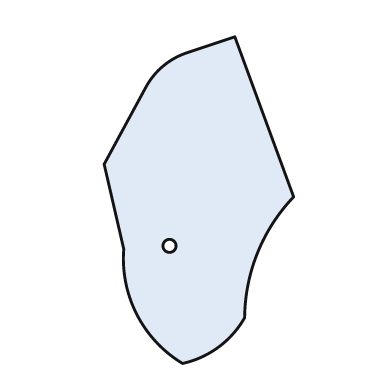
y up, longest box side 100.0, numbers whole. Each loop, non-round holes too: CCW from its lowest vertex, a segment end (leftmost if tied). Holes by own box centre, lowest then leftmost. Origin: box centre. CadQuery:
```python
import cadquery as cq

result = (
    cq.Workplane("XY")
    .moveTo(-5.0, -50.0)
    .threePointArc((6.0, -45.0), (14.0, -36.0))
    .threePointArc((18.0, -16.0), (29.0, 1.0))
    .lineTo(11.0, 50.0)
    .lineTo(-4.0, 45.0)
    .threePointArc((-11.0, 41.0), (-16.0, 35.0))
    .lineTo(-29.0, 11.0)
    .lineTo(-23.0, -15.0)
    .threePointArc((-19.0, -35.0), (-5.0, -50.0))
    .close()
    .moveTo(-9.0, -14.0)
    .circle(2.0)
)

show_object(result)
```